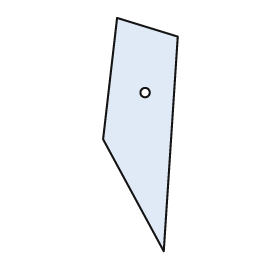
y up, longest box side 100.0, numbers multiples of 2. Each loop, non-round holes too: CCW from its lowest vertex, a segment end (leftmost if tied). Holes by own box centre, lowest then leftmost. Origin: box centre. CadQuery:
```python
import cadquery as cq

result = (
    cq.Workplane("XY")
    .moveTo(10.0, -50.0)
    .lineTo(16.0, 42.0)
    .lineTo(-10.0, 50.0)
    .lineTo(-16.0, -2.0)
    .close()
    .moveTo(2.0, 18.0)
    .circle(2.0)
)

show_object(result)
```